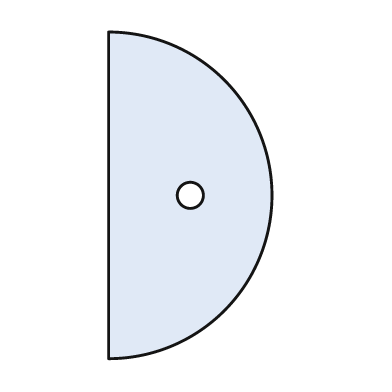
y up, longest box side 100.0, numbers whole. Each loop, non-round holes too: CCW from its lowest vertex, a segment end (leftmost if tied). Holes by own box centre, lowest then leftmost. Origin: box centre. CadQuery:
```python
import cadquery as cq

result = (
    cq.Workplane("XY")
    .moveTo(-25.0, -50.0)
    .threePointArc((25.0, 0.0), (-25.0, 50.0))
    .close()
    .moveTo(0.0, 0.0)
    .circle(4.0)
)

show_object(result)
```